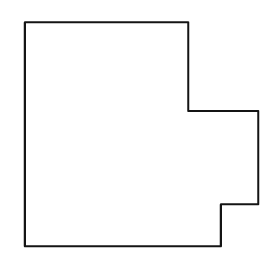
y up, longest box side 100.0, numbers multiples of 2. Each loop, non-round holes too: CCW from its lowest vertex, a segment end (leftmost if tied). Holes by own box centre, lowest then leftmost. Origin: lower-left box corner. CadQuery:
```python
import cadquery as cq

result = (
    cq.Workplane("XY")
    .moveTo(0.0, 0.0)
    .lineTo(84.0, 0.0)
    .lineTo(84.0, 18.0)
    .lineTo(100.0, 18.0)
    .lineTo(100.0, 58.0)
    .lineTo(70.0, 58.0)
    .lineTo(70.0, 96.0)
    .lineTo(0.0, 96.0)
    .close()
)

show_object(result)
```